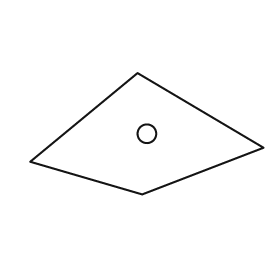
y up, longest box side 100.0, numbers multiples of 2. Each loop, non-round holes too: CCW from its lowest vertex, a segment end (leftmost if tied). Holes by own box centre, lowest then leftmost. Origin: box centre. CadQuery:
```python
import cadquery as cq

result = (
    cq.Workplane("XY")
    .moveTo(-2.0, -26.0)
    .lineTo(50.0, -6.0)
    .lineTo(-4.0, 26.0)
    .lineTo(-50.0, -12.0)
    .close()
    .moveTo(0.0, 0.0)
    .circle(4.0)
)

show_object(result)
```